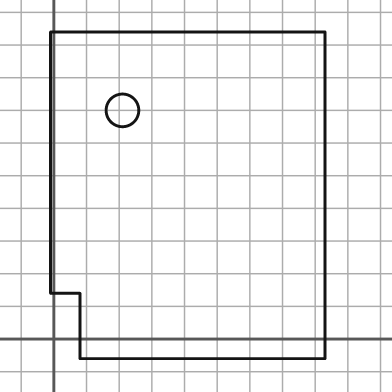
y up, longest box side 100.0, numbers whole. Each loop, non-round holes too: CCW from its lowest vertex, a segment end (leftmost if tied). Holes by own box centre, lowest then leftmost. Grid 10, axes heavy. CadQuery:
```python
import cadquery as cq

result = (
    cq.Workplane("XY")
    .moveTo(8.0, -6.0)
    .lineTo(83.0, -6.0)
    .lineTo(83.0, 94.0)
    .lineTo(-1.0, 94.0)
    .lineTo(-1.0, 14.0)
    .lineTo(8.0, 14.0)
    .close()
    .moveTo(21.0, 70.0)
    .circle(5.0)
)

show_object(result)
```